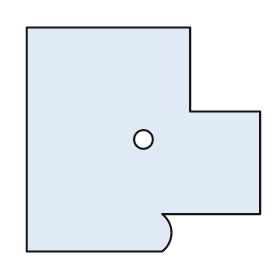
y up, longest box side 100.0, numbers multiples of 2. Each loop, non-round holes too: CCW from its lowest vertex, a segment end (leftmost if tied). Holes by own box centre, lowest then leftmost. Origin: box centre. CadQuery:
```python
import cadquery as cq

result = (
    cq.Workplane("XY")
    .moveTo(-50.0, -48.0)
    .lineTo(8.0, -48.0)
    .threePointArc((12.0, -40.0), (8.0, -32.0))
    .lineTo(50.0, -32.0)
    .lineTo(50.0, 12.0)
    .lineTo(20.0, 12.0)
    .lineTo(20.0, 48.0)
    .lineTo(-50.0, 48.0)
    .close()
    .moveTo(0.0, 0.0)
    .circle(4.0)
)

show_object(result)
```